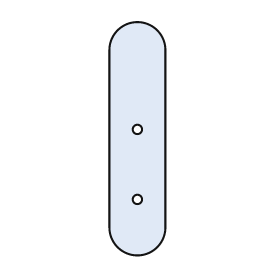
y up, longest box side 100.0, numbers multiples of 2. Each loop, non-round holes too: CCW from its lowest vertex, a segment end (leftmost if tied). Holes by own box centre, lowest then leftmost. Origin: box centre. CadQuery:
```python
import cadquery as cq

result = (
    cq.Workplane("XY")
    .moveTo(-12.0, -38.0)
    .threePointArc((0.0, -50.0), (12.0, -38.0))
    .lineTo(12.0, 38.0)
    .threePointArc((0.0, 50.0), (-12.0, 38.0))
    .close()
    .moveTo(0.0, -26.0)
    .circle(2.0)
    .moveTo(0.0, 4.0)
    .circle(2.0)
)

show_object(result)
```